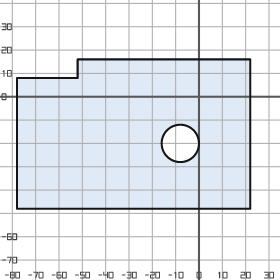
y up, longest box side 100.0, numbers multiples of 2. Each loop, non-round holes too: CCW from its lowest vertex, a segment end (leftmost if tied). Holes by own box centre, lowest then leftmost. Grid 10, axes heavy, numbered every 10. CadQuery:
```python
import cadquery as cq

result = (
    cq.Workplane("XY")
    .moveTo(-78.0, -48.0)
    .lineTo(22.0, -48.0)
    .lineTo(22.0, 16.0)
    .lineTo(-52.0, 16.0)
    .lineTo(-52.0, 8.0)
    .lineTo(-78.0, 8.0)
    .close()
    .moveTo(-8.0, -20.0)
    .circle(8.0)
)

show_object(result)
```